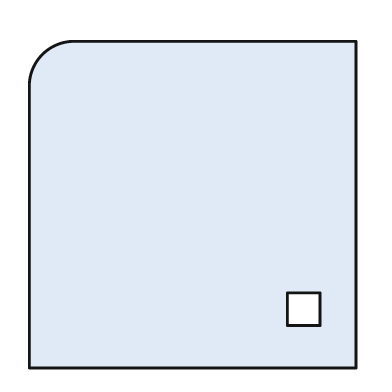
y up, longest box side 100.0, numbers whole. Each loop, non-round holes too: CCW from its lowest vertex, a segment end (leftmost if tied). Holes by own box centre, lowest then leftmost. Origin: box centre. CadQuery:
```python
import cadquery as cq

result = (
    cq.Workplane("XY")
    .moveTo(-50.0, -50.0)
    .lineTo(50.0, -50.0)
    .lineTo(50.0, 50.0)
    .lineTo(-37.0, 50.0)
    .threePointArc((-46.0, 46.0), (-50.0, 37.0))
    .close()
    .moveTo(29.0, -37.0)
    .lineTo(39.0, -37.0)
    .lineTo(39.0, -27.0)
    .lineTo(29.0, -27.0)
    .close()
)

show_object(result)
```